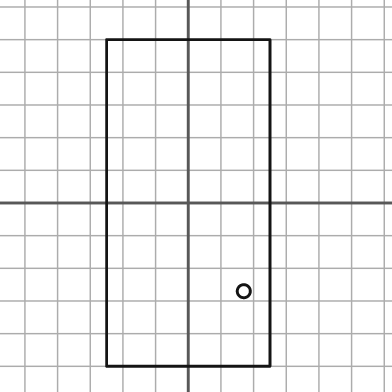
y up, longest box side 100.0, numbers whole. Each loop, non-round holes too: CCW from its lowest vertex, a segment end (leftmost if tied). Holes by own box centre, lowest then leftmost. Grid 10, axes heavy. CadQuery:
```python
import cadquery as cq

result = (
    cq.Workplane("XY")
    .moveTo(-25.0, -50.0)
    .lineTo(25.0, -50.0)
    .lineTo(25.0, 50.0)
    .lineTo(-25.0, 50.0)
    .close()
    .moveTo(17.0, -27.0)
    .circle(2.0)
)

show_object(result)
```